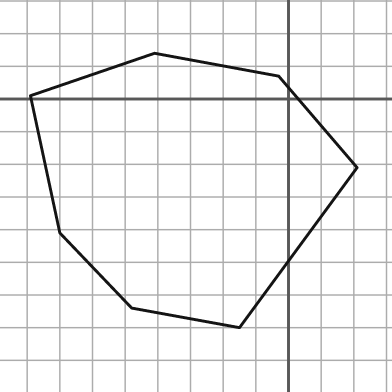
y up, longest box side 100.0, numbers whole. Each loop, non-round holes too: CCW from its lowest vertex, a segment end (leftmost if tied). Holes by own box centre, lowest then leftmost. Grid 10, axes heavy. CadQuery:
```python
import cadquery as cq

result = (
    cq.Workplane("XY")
    .moveTo(-15.0, -70.0)
    .lineTo(21.0, -21.0)
    .lineTo(-3.0, 7.0)
    .lineTo(-41.0, 14.0)
    .lineTo(-79.0, 1.0)
    .lineTo(-70.0, -41.0)
    .lineTo(-48.0, -64.0)
    .close()
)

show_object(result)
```